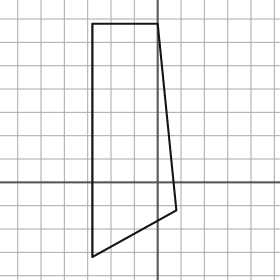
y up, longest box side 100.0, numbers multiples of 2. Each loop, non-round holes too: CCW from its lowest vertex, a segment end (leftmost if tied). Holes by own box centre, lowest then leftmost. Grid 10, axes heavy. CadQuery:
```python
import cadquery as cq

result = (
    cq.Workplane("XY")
    .moveTo(-28.0, -32.0)
    .lineTo(8.0, -12.0)
    .lineTo(0.0, 68.0)
    .lineTo(-28.0, 68.0)
    .close()
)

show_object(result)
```